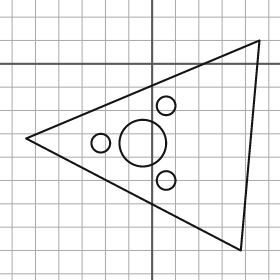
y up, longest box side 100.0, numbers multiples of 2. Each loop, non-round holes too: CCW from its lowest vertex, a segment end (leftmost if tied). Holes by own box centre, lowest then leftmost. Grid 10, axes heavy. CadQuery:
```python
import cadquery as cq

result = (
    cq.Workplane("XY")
    .moveTo(38.0, -80.0)
    .lineTo(46.0, 10.0)
    .lineTo(-54.0, -32.0)
    .close()
    .moveTo(6.0, -50.0)
    .circle(4.0)
    .moveTo(-22.0, -34.0)
    .circle(4.0)
    .moveTo(-4.0, -34.0)
    .circle(10.0)
    .moveTo(6.0, -18.0)
    .circle(4.0)
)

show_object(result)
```